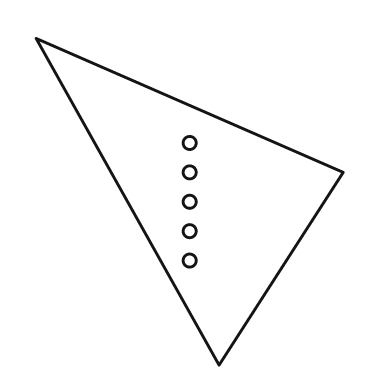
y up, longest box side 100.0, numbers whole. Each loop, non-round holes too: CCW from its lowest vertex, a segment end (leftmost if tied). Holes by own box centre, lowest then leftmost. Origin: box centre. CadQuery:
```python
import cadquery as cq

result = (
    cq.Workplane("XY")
    .moveTo(9.0, -50.0)
    .lineTo(47.0, 9.0)
    .lineTo(-47.0, 50.0)
    .close()
    .moveTo(0.0, -18.0)
    .circle(2.0)
    .moveTo(0.0, -9.0)
    .circle(2.0)
    .moveTo(0.0, 0.0)
    .circle(2.0)
    .moveTo(0.0, 9.0)
    .circle(2.0)
    .moveTo(0.0, 18.0)
    .circle(2.0)
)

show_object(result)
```